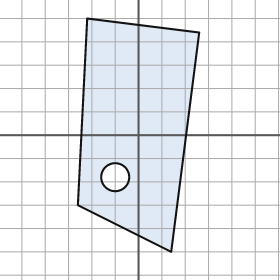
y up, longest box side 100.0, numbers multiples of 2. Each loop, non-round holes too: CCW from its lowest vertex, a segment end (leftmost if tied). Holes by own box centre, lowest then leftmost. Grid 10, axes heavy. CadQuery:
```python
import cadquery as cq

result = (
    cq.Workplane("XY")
    .moveTo(14.0, -50.0)
    .lineTo(26.0, 44.0)
    .lineTo(-22.0, 50.0)
    .lineTo(-26.0, -30.0)
    .close()
    .moveTo(-10.0, -18.0)
    .circle(6.0)
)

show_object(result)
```